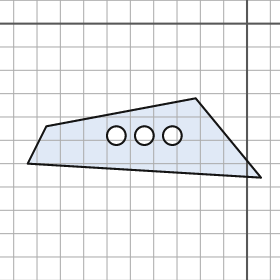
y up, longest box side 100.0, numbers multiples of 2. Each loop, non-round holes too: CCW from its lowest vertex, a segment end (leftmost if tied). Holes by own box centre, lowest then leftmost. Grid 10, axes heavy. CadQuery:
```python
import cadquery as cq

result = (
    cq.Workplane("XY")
    .moveTo(6.0, -66.0)
    .lineTo(-22.0, -32.0)
    .lineTo(-86.0, -44.0)
    .lineTo(-94.0, -60.0)
    .close()
    .moveTo(-56.0, -48.0)
    .circle(4.0)
    .moveTo(-44.0, -48.0)
    .circle(4.0)
    .moveTo(-32.0, -48.0)
    .circle(4.0)
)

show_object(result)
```